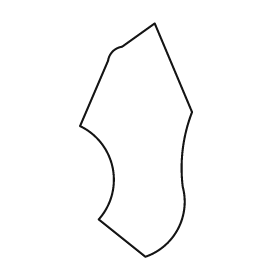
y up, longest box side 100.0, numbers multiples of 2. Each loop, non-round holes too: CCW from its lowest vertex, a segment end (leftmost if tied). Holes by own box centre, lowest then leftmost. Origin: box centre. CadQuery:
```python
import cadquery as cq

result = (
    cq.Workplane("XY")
    .moveTo(4.0, -50.0)
    .threePointArc((18.0, -38.0), (20.0, -20.0))
    .threePointArc((20.0, -4.0), (24.0, 12.0))
    .lineTo(8.0, 50.0)
    .lineTo(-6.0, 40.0)
    .threePointArc((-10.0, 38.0), (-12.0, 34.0))
    .lineTo(-24.0, 6.0)
    .threePointArc((-10.0, -12.0), (-16.0, -34.0))
    .close()
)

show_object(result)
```